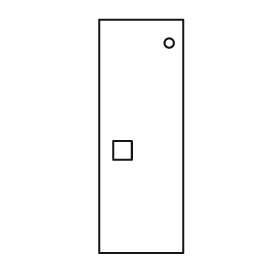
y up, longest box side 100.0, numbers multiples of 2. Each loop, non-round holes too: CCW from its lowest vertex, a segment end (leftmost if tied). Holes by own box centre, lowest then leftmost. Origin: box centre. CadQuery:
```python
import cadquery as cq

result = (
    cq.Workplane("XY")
    .moveTo(-18.0, -50.0)
    .lineTo(18.0, -50.0)
    .lineTo(18.0, 50.0)
    .lineTo(-18.0, 50.0)
    .close()
    .moveTo(-12.0, -10.0)
    .lineTo(-4.0, -10.0)
    .lineTo(-4.0, -2.0)
    .lineTo(-12.0, -2.0)
    .close()
    .moveTo(12.0, 40.0)
    .circle(2.0)
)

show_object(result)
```